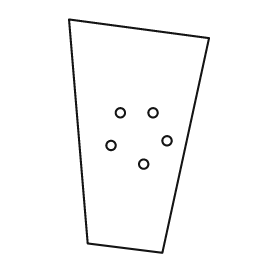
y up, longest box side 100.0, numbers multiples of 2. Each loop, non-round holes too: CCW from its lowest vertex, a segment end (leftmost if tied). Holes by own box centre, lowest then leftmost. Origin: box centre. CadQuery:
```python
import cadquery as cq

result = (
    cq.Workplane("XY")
    .moveTo(10.0, -50.0)
    .lineTo(30.0, 42.0)
    .lineTo(-30.0, 50.0)
    .lineTo(-22.0, -46.0)
    .close()
    .moveTo(2.0, -12.0)
    .circle(2.0)
    .moveTo(-12.0, -4.0)
    .circle(2.0)
    .moveTo(12.0, -2.0)
    .circle(2.0)
    .moveTo(-8.0, 10.0)
    .circle(2.0)
    .moveTo(6.0, 10.0)
    .circle(2.0)
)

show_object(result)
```